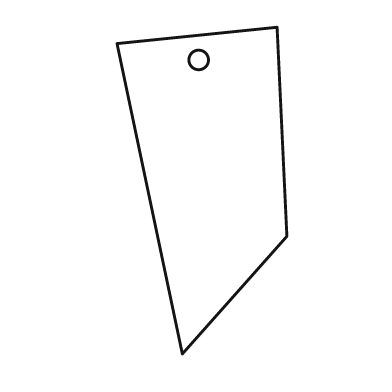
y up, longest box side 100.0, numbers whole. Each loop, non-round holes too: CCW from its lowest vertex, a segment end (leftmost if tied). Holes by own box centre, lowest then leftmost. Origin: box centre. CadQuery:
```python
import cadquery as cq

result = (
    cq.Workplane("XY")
    .moveTo(-6.0, -50.0)
    .lineTo(26.0, -14.0)
    .lineTo(23.0, 50.0)
    .lineTo(-26.0, 45.0)
    .close()
    .moveTo(-1.0, 40.0)
    .circle(3.0)
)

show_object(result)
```